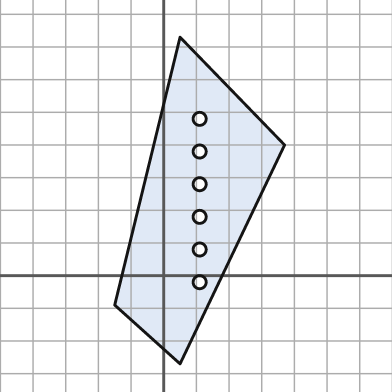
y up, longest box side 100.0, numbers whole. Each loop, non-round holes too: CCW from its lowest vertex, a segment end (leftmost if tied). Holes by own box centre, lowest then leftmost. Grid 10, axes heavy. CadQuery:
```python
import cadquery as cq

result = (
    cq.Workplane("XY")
    .moveTo(5.0, -27.0)
    .lineTo(37.0, 40.0)
    .lineTo(5.0, 73.0)
    .lineTo(-15.0, -9.0)
    .close()
    .moveTo(11.0, -2.0)
    .circle(2.0)
    .moveTo(11.0, 8.0)
    .circle(2.0)
    .moveTo(11.0, 18.0)
    .circle(2.0)
    .moveTo(11.0, 28.0)
    .circle(2.0)
    .moveTo(11.0, 38.0)
    .circle(2.0)
    .moveTo(11.0, 48.0)
    .circle(2.0)
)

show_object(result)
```